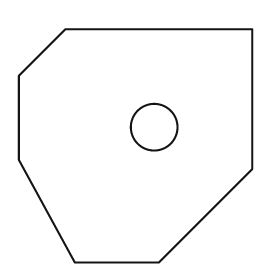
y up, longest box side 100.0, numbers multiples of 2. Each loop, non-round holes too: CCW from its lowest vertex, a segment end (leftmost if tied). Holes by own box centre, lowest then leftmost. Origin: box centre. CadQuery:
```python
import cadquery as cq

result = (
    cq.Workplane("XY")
    .moveTo(-26.0, -50.0)
    .lineTo(10.0, -50.0)
    .lineTo(50.0, -10.0)
    .lineTo(50.0, 50.0)
    .lineTo(-30.0, 50.0)
    .lineTo(-50.0, 30.0)
    .lineTo(-50.0, -6.0)
    .close()
    .moveTo(8.0, 8.0)
    .circle(10.0)
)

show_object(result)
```